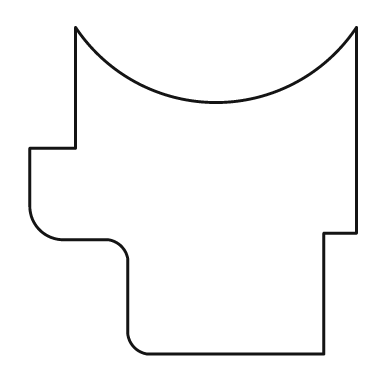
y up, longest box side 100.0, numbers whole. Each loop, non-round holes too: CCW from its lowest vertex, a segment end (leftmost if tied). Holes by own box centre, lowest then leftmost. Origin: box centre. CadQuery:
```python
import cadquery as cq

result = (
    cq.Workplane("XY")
    .moveTo(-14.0, -50.0)
    .lineTo(40.0, -50.0)
    .lineTo(40.0, -13.0)
    .lineTo(50.0, -13.0)
    .lineTo(50.0, 50.0)
    .threePointArc((7.0, 27.0), (-36.0, 50.0))
    .lineTo(-36.0, 13.0)
    .lineTo(-50.0, 13.0)
    .lineTo(-50.0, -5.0)
    .threePointArc((-47.0, -12.0), (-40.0, -15.0))
    .lineTo(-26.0, -15.0)
    .threePointArc((-22.0, -17.0), (-20.0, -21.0))
    .lineTo(-20.0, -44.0)
    .threePointArc((-18.0, -48.0), (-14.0, -50.0))
    .close()
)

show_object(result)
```